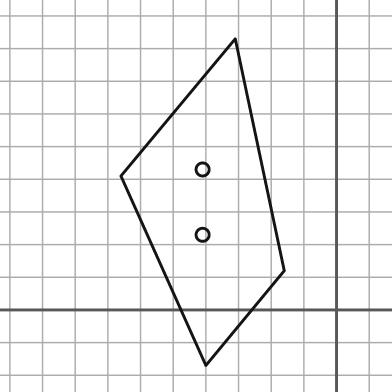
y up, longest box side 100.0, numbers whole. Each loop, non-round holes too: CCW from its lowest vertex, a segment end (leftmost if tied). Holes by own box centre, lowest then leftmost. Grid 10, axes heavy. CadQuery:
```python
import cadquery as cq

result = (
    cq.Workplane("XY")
    .moveTo(-40.0, -17.0)
    .lineTo(-16.0, 12.0)
    .lineTo(-31.0, 83.0)
    .lineTo(-66.0, 41.0)
    .close()
    .moveTo(-41.0, 23.0)
    .circle(2.0)
    .moveTo(-41.0, 43.0)
    .circle(2.0)
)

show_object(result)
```